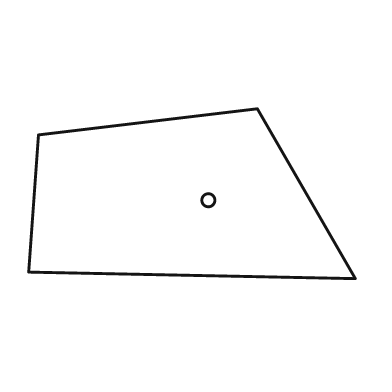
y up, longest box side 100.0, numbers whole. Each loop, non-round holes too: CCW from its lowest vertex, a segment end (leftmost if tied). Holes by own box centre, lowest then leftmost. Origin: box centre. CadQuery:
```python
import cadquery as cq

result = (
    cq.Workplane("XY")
    .moveTo(50.0, -26.0)
    .lineTo(20.0, 26.0)
    .lineTo(-47.0, 18.0)
    .lineTo(-50.0, -24.0)
    .close()
    .moveTo(5.0, -2.0)
    .circle(2.0)
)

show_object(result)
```